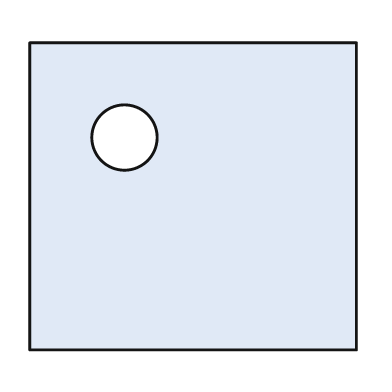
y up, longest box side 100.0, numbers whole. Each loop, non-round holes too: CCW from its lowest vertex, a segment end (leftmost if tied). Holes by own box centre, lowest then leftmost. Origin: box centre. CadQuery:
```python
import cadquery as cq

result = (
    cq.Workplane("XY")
    .moveTo(-50.0, -47.0)
    .lineTo(50.0, -47.0)
    .lineTo(50.0, 47.0)
    .lineTo(-50.0, 47.0)
    .close()
    .moveTo(-21.0, 18.0)
    .circle(10.0)
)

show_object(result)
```